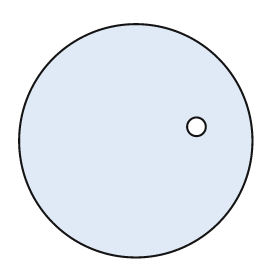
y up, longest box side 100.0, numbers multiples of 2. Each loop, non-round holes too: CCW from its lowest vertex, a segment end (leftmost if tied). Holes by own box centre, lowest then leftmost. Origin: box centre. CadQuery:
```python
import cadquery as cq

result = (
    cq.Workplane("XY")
    .moveTo(0.0, 0.0)
    .circle(50.0)
    .moveTo(26.0, 6.0)
    .circle(4.0)
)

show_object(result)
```